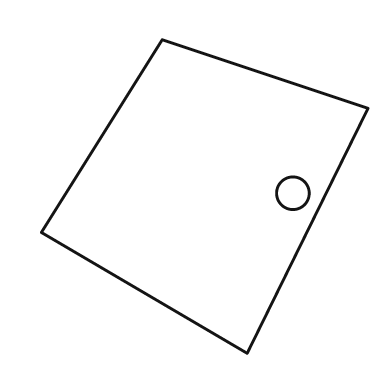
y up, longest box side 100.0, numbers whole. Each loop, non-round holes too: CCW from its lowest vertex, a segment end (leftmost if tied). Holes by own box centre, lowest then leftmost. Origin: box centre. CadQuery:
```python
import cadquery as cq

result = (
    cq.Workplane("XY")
    .moveTo(13.0, -48.0)
    .lineTo(50.0, 27.0)
    .lineTo(-13.0, 48.0)
    .lineTo(-50.0, -11.0)
    .close()
    .moveTo(27.0, 1.0)
    .circle(5.0)
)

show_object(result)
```